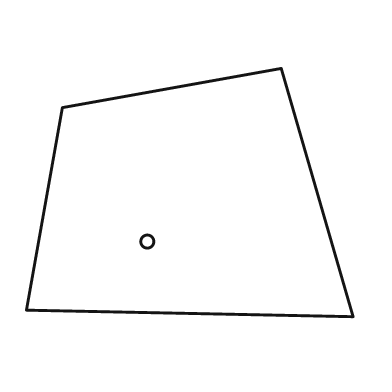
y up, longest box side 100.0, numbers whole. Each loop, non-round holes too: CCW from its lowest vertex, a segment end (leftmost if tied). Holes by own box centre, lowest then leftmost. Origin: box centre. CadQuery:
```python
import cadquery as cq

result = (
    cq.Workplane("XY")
    .moveTo(50.0, -38.0)
    .lineTo(28.0, 38.0)
    .lineTo(-39.0, 26.0)
    .lineTo(-50.0, -36.0)
    .close()
    .moveTo(-13.0, -15.0)
    .circle(2.0)
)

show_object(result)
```